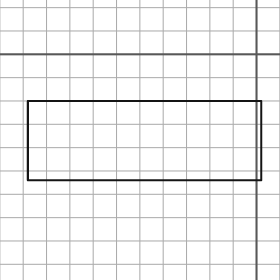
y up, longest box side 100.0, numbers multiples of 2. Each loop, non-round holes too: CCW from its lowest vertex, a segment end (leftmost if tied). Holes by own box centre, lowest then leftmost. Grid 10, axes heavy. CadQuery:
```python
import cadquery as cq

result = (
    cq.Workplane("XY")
    .moveTo(-98.0, -54.0)
    .lineTo(2.0, -54.0)
    .lineTo(2.0, -20.0)
    .lineTo(-98.0, -20.0)
    .close()
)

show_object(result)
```